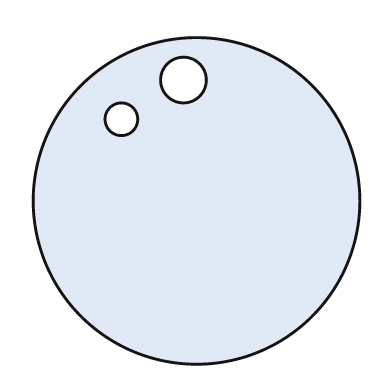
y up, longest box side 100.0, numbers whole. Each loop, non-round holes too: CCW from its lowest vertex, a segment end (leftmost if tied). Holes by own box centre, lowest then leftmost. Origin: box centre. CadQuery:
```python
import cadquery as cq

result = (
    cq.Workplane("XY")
    .moveTo(0.0, 0.0)
    .circle(50.0)
    .moveTo(-23.0, 25.0)
    .circle(5.0)
    .moveTo(-4.0, 37.0)
    .circle(7.0)
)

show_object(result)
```